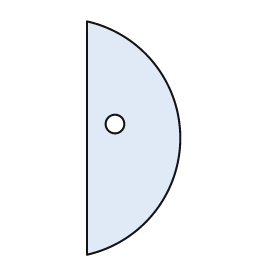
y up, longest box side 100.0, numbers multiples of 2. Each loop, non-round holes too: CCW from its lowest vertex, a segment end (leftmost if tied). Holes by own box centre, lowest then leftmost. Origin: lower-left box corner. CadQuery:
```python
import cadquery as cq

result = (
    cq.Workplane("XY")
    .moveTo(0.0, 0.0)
    .threePointArc((40.0, 50.0), (0.0, 100.0))
    .close()
    .moveTo(12.0, 56.0)
    .circle(4.0)
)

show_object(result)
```